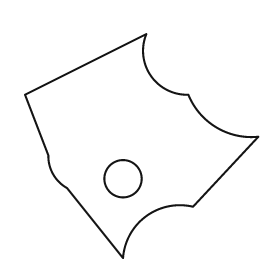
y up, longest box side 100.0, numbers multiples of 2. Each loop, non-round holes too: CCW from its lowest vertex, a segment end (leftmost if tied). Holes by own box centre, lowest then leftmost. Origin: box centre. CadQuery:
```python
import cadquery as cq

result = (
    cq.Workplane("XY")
    .moveTo(-8.0, -48.0)
    .threePointArc((2.0, -30.0), (22.0, -26.0))
    .lineTo(50.0, 4.0)
    .threePointArc((32.0, 8.0), (20.0, 22.0))
    .threePointArc((4.0, 30.0), (2.0, 48.0))
    .lineTo(-50.0, 22.0)
    .lineTo(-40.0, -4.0)
    .threePointArc((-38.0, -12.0), (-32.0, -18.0))
    .close()
    .moveTo(-8.0, -14.0)
    .circle(8.0)
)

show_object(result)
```